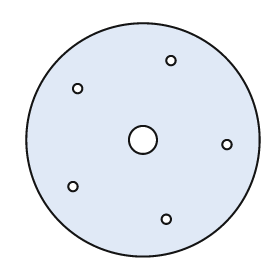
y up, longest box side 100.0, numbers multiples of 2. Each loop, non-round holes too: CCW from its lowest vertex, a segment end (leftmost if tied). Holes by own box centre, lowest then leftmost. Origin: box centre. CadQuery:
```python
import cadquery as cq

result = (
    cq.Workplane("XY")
    .moveTo(0.0, 0.0)
    .circle(50.0)
    .moveTo(10.0, -34.0)
    .circle(2.0)
    .moveTo(-30.0, -20.0)
    .circle(2.0)
    .moveTo(36.0, -2.0)
    .circle(2.0)
    .moveTo(0.0, 0.0)
    .circle(6.0)
    .moveTo(-28.0, 22.0)
    .circle(2.0)
    .moveTo(12.0, 34.0)
    .circle(2.0)
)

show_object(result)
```